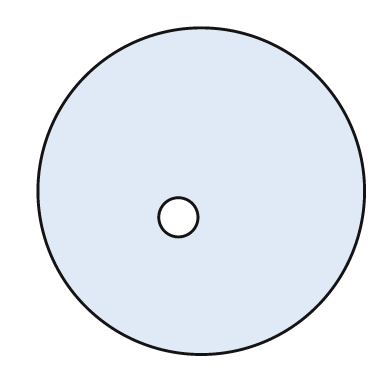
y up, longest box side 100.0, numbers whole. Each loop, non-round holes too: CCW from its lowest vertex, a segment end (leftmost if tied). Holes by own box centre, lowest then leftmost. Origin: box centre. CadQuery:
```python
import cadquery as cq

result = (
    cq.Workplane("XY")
    .moveTo(0.0, 0.0)
    .circle(50.0)
    .moveTo(-7.0, -8.0)
    .circle(6.0)
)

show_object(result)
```